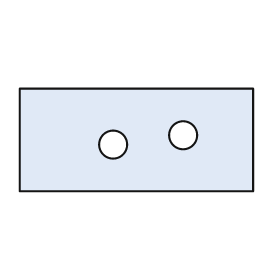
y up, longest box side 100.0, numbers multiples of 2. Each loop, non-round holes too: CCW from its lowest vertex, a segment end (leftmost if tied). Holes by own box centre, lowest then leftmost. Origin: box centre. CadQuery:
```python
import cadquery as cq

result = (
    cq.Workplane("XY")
    .moveTo(-50.0, -22.0)
    .lineTo(50.0, -22.0)
    .lineTo(50.0, 22.0)
    .lineTo(-50.0, 22.0)
    .close()
    .moveTo(-10.0, -2.0)
    .circle(6.0)
    .moveTo(20.0, 2.0)
    .circle(6.0)
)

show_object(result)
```